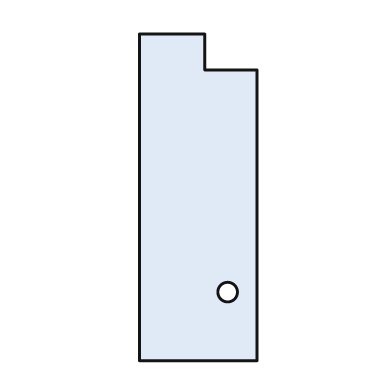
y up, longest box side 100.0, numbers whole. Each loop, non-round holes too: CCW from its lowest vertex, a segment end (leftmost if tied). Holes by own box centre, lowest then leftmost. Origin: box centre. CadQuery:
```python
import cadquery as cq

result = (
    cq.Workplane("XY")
    .moveTo(-18.0, -50.0)
    .lineTo(18.0, -50.0)
    .lineTo(18.0, 39.0)
    .lineTo(2.0, 39.0)
    .lineTo(2.0, 50.0)
    .lineTo(-18.0, 50.0)
    .close()
    .moveTo(9.0, -29.0)
    .circle(3.0)
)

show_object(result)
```